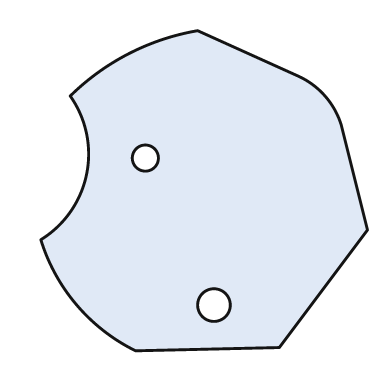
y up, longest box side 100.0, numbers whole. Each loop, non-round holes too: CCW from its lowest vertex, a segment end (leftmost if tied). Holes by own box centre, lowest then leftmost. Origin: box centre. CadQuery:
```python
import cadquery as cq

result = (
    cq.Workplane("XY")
    .moveTo(-21.0, -49.0)
    .lineTo(23.0, -48.0)
    .lineTo(50.0, -12.0)
    .lineTo(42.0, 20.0)
    .threePointArc((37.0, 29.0), (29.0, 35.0))
    .lineTo(-2.0, 49.0)
    .threePointArc((-23.0, 42.0), (-41.0, 29.0))
    .threePointArc((-36.0, 5.0), (-50.0, -15.0))
    .threePointArc((-39.0, -35.0), (-21.0, -49.0))
    .close()
    .moveTo(3.0, -35.0)
    .circle(5.0)
    .moveTo(-18.0, 10.0)
    .circle(4.0)
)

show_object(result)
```